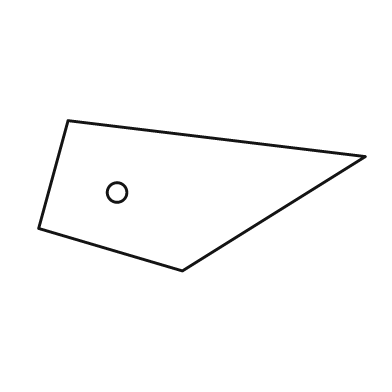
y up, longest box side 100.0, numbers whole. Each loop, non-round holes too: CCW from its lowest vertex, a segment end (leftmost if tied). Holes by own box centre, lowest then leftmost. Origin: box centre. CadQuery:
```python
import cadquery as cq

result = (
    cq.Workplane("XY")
    .moveTo(-6.0, -23.0)
    .lineTo(50.0, 12.0)
    .lineTo(-41.0, 23.0)
    .lineTo(-50.0, -10.0)
    .close()
    .moveTo(-26.0, 1.0)
    .circle(3.0)
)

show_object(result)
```